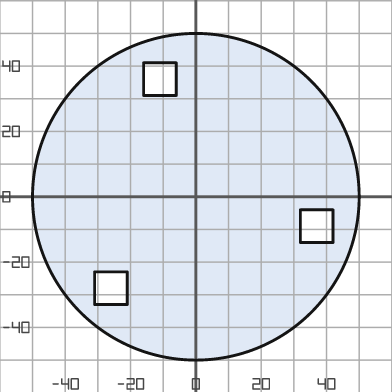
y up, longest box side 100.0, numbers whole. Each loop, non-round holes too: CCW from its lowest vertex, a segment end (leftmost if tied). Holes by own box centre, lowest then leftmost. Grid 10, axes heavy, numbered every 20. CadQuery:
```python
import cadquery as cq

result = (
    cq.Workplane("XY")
    .moveTo(0.0, 0.0)
    .circle(50.0)
    .moveTo(-31.0, -33.0)
    .lineTo(-21.0, -33.0)
    .lineTo(-21.0, -23.0)
    .lineTo(-31.0, -23.0)
    .close()
    .moveTo(32.0, -14.0)
    .lineTo(42.0, -14.0)
    .lineTo(42.0, -4.0)
    .lineTo(32.0, -4.0)
    .close()
    .moveTo(-16.0, 31.0)
    .lineTo(-6.0, 31.0)
    .lineTo(-6.0, 41.0)
    .lineTo(-16.0, 41.0)
    .close()
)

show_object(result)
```